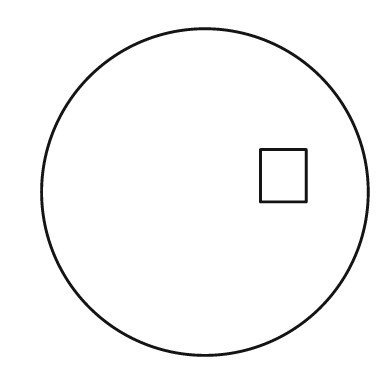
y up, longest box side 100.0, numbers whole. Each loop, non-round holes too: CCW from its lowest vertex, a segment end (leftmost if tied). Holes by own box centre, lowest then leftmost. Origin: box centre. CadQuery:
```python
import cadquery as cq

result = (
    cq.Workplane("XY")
    .moveTo(0.0, 0.0)
    .circle(50.0)
    .moveTo(17.0, -3.0)
    .lineTo(31.0, -3.0)
    .lineTo(31.0, 13.0)
    .lineTo(17.0, 13.0)
    .close()
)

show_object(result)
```